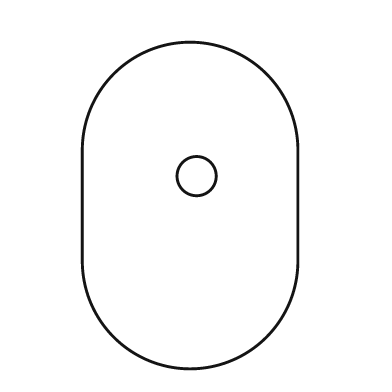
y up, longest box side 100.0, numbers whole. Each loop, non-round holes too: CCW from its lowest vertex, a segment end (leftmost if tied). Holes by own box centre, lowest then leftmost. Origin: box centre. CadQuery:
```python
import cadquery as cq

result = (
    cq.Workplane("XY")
    .moveTo(-33.0, -17.0)
    .threePointArc((0.0, -50.0), (33.0, -17.0))
    .lineTo(33.0, 17.0)
    .threePointArc((0.0, 50.0), (-33.0, 17.0))
    .close()
    .moveTo(2.0, 9.0)
    .circle(6.0)
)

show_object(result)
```